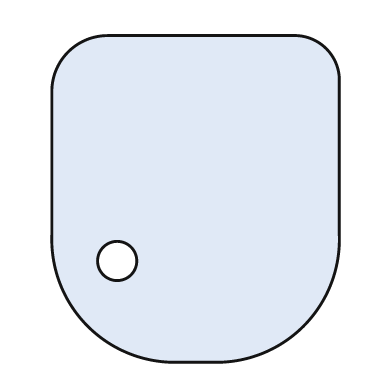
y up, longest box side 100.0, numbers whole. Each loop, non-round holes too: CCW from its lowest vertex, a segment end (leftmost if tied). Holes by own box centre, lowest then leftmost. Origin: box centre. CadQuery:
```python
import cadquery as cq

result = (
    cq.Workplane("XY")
    .moveTo(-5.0, -50.0)
    .lineTo(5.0, -50.0)
    .threePointArc((33.0, -39.0), (44.0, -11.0))
    .lineTo(44.0, 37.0)
    .threePointArc((40.0, 46.0), (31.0, 50.0))
    .lineTo(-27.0, 50.0)
    .threePointArc((-39.0, 45.0), (-44.0, 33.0))
    .lineTo(-44.0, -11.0)
    .threePointArc((-33.0, -39.0), (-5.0, -50.0))
    .close()
    .moveTo(-24.0, -19.0)
    .circle(6.0)
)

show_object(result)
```